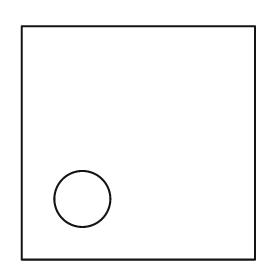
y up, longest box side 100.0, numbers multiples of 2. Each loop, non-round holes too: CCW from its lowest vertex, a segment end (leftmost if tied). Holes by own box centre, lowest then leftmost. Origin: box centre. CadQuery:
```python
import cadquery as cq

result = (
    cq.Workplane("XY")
    .moveTo(-50.0, -50.0)
    .lineTo(50.0, -50.0)
    .lineTo(50.0, 50.0)
    .lineTo(-50.0, 50.0)
    .close()
    .moveTo(-24.0, -24.0)
    .circle(12.0)
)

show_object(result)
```